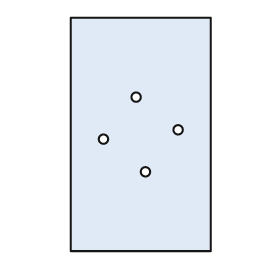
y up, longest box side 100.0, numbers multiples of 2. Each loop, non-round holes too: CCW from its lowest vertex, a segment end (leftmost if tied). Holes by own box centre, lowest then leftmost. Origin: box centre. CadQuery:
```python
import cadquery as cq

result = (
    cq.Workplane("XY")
    .moveTo(-30.0, -50.0)
    .lineTo(30.0, -50.0)
    .lineTo(30.0, 50.0)
    .lineTo(-30.0, 50.0)
    .close()
    .moveTo(2.0, -16.0)
    .circle(2.0)
    .moveTo(-16.0, -2.0)
    .circle(2.0)
    .moveTo(16.0, 2.0)
    .circle(2.0)
    .moveTo(-2.0, 16.0)
    .circle(2.0)
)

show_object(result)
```